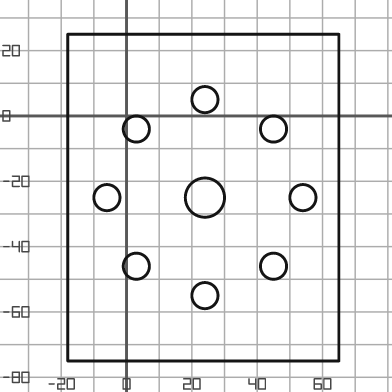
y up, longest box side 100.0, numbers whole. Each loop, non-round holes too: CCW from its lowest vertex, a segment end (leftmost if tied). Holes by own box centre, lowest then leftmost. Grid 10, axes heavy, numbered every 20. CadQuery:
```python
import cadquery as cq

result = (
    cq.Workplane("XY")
    .moveTo(-18.0, -75.0)
    .lineTo(65.0, -75.0)
    .lineTo(65.0, 25.0)
    .lineTo(-18.0, 25.0)
    .close()
    .moveTo(24.0, -55.0)
    .circle(4.0)
    .moveTo(3.0, -46.0)
    .circle(4.0)
    .moveTo(45.0, -46.0)
    .circle(4.0)
    .moveTo(-6.0, -25.0)
    .circle(4.0)
    .moveTo(24.0, -25.0)
    .circle(6.0)
    .moveTo(54.0, -25.0)
    .circle(4.0)
    .moveTo(3.0, -4.0)
    .circle(4.0)
    .moveTo(45.0, -4.0)
    .circle(4.0)
    .moveTo(24.0, 5.0)
    .circle(4.0)
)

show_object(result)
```